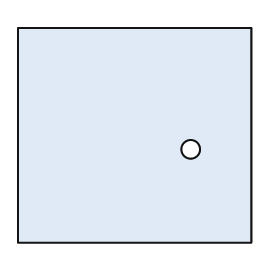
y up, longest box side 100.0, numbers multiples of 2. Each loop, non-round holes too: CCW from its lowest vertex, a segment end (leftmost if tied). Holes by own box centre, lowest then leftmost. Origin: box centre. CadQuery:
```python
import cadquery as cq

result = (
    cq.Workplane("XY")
    .moveTo(-50.0, -46.0)
    .lineTo(50.0, -46.0)
    .lineTo(50.0, 46.0)
    .lineTo(-50.0, 46.0)
    .close()
    .moveTo(24.0, -6.0)
    .circle(4.0)
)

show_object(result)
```